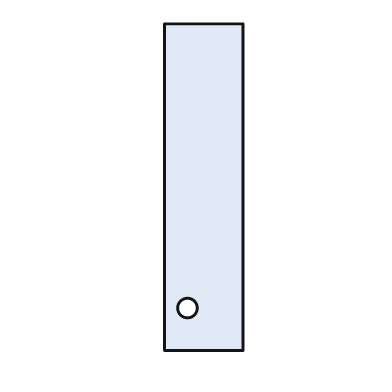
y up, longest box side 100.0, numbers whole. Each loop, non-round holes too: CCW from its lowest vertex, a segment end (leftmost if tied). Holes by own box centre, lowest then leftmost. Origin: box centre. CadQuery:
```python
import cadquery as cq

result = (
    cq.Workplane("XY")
    .moveTo(-12.0, -50.0)
    .lineTo(12.0, -50.0)
    .lineTo(12.0, 50.0)
    .lineTo(-12.0, 50.0)
    .close()
    .moveTo(-5.0, -37.0)
    .circle(3.0)
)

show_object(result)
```